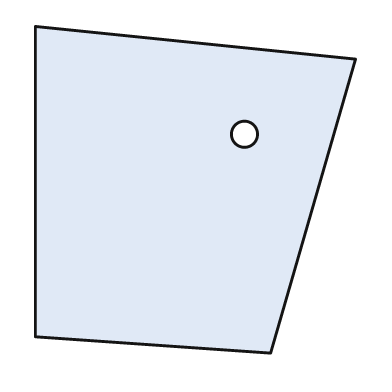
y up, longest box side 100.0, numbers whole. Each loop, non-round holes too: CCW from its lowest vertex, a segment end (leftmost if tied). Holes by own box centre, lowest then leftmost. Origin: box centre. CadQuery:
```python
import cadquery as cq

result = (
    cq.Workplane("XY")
    .moveTo(23.0, -50.0)
    .lineTo(49.0, 40.0)
    .lineTo(-49.0, 50.0)
    .lineTo(-49.0, -45.0)
    .close()
    .moveTo(15.0, 17.0)
    .circle(4.0)
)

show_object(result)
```